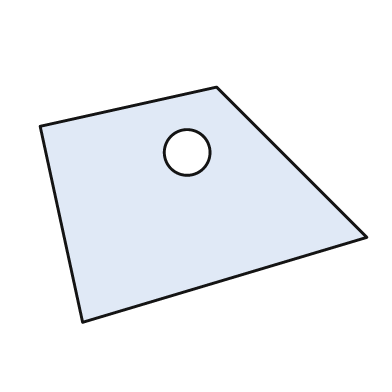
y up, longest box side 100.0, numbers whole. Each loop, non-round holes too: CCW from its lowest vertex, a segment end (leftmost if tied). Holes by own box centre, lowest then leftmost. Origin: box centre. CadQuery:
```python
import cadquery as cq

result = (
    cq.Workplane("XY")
    .moveTo(-37.0, -36.0)
    .lineTo(50.0, -10.0)
    .lineTo(4.0, 36.0)
    .lineTo(-50.0, 24.0)
    .close()
    .moveTo(-5.0, 16.0)
    .circle(7.0)
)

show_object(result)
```